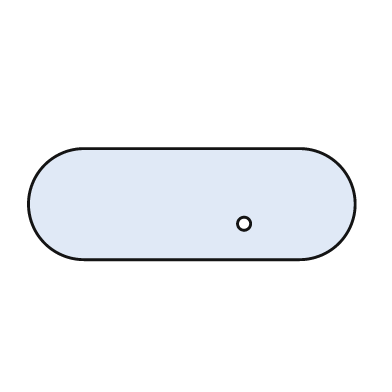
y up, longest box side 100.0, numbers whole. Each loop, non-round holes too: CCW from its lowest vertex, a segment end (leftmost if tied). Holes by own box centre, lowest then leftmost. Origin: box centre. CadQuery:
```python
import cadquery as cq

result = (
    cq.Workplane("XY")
    .moveTo(-33.0, -17.0)
    .lineTo(33.0, -17.0)
    .threePointArc((50.0, 0.0), (33.0, 17.0))
    .lineTo(-33.0, 17.0)
    .threePointArc((-50.0, 0.0), (-33.0, -17.0))
    .close()
    .moveTo(16.0, -6.0)
    .circle(2.0)
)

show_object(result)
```